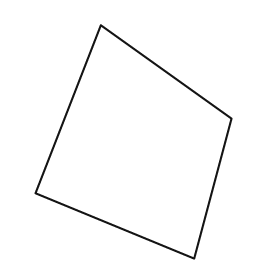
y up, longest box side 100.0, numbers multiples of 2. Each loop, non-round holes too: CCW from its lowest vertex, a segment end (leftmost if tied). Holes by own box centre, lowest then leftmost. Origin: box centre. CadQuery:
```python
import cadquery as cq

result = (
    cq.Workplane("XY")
    .moveTo(26.0, -50.0)
    .lineTo(42.0, 10.0)
    .lineTo(-14.0, 50.0)
    .lineTo(-42.0, -22.0)
    .close()
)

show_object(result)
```